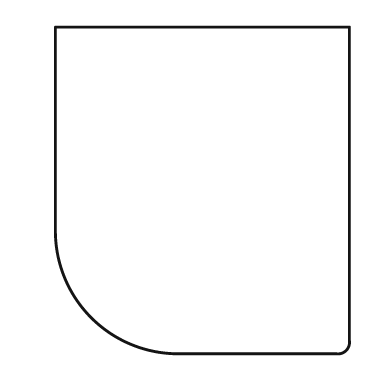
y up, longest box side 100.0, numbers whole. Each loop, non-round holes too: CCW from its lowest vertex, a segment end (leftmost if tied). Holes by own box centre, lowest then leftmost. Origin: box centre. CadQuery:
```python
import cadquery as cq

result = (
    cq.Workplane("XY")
    .moveTo(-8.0, -50.0)
    .lineTo(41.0, -50.0)
    .threePointArc((44.0, -49.0), (45.0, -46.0))
    .lineTo(45.0, 50.0)
    .lineTo(-45.0, 50.0)
    .lineTo(-45.0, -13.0)
    .threePointArc((-34.0, -39.0), (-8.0, -50.0))
    .close()
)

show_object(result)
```